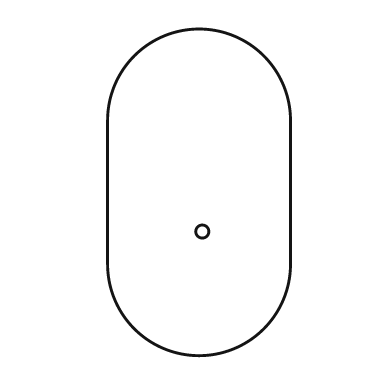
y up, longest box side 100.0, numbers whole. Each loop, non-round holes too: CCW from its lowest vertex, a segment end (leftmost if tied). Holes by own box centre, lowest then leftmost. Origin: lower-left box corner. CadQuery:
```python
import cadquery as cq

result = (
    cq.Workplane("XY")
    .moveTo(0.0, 28.0)
    .threePointArc((28.0, 0.0), (56.0, 28.0))
    .lineTo(56.0, 72.0)
    .threePointArc((28.0, 100.0), (0.0, 72.0))
    .close()
    .moveTo(29.0, 38.0)
    .circle(2.0)
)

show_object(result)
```